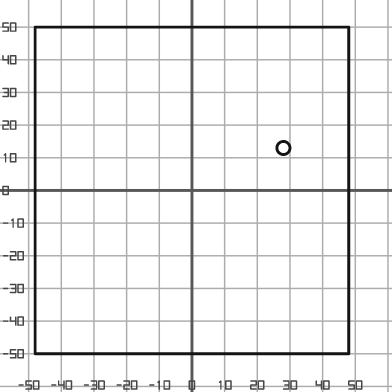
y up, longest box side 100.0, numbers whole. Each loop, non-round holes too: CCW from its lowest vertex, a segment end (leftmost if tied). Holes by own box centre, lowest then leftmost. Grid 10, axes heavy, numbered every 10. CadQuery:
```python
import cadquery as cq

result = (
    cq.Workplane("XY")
    .moveTo(-48.0, -50.0)
    .lineTo(48.0, -50.0)
    .lineTo(48.0, 50.0)
    .lineTo(-48.0, 50.0)
    .close()
    .moveTo(28.0, 13.0)
    .circle(2.0)
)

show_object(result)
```